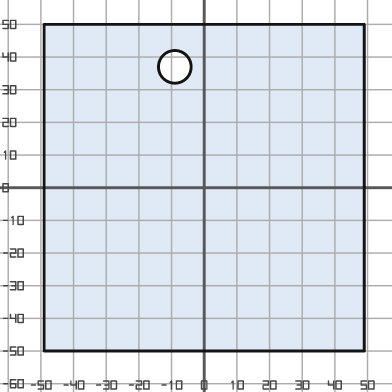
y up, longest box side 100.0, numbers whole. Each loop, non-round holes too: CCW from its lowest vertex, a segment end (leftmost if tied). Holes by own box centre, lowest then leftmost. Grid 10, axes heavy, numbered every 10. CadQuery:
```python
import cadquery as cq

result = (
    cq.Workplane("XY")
    .moveTo(-49.0, -50.0)
    .lineTo(49.0, -50.0)
    .lineTo(49.0, 50.0)
    .lineTo(-49.0, 50.0)
    .close()
    .moveTo(-9.0, 37.0)
    .circle(5.0)
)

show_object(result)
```